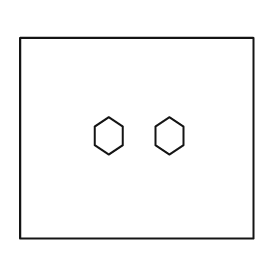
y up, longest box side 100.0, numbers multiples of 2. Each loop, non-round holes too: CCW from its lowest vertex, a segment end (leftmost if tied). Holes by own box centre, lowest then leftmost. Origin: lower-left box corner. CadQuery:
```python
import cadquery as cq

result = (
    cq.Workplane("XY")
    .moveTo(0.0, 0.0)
    .lineTo(100.0, 0.0)
    .lineTo(100.0, 86.0)
    .lineTo(0.0, 86.0)
    .close()
    .moveTo(38.0, 36.0)
    .lineTo(44.0, 40.0)
    .lineTo(44.0, 48.0)
    .lineTo(38.0, 52.0)
    .lineTo(32.0, 48.0)
    .lineTo(32.0, 40.0)
    .close()
    .moveTo(64.0, 36.0)
    .lineTo(70.0, 40.0)
    .lineTo(70.0, 48.0)
    .lineTo(64.0, 52.0)
    .lineTo(58.0, 48.0)
    .lineTo(58.0, 40.0)
    .close()
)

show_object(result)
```